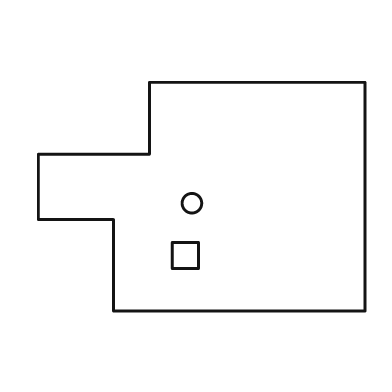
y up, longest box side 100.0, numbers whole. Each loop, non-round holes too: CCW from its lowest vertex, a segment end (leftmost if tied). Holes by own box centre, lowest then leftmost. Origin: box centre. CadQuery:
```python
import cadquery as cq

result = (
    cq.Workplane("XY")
    .moveTo(-27.0, -35.0)
    .lineTo(50.0, -35.0)
    .lineTo(50.0, 35.0)
    .lineTo(-16.0, 35.0)
    .lineTo(-16.0, 13.0)
    .lineTo(-50.0, 13.0)
    .lineTo(-50.0, -7.0)
    .lineTo(-27.0, -7.0)
    .close()
    .moveTo(-9.0, -22.0)
    .lineTo(-1.0, -22.0)
    .lineTo(-1.0, -14.0)
    .lineTo(-9.0, -14.0)
    .close()
    .moveTo(-3.0, -2.0)
    .circle(3.0)
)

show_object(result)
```